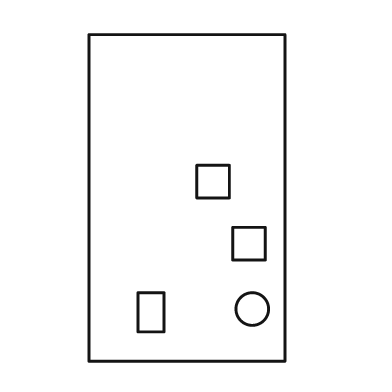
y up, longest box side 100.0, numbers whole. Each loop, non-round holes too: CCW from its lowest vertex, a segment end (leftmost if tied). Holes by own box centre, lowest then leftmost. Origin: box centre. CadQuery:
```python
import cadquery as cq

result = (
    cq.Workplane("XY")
    .moveTo(-30.0, -50.0)
    .lineTo(30.0, -50.0)
    .lineTo(30.0, 50.0)
    .lineTo(-30.0, 50.0)
    .close()
    .moveTo(-15.0, -41.0)
    .lineTo(-7.0, -41.0)
    .lineTo(-7.0, -29.0)
    .lineTo(-15.0, -29.0)
    .close()
    .moveTo(20.0, -34.0)
    .circle(5.0)
    .moveTo(14.0, -19.0)
    .lineTo(24.0, -19.0)
    .lineTo(24.0, -9.0)
    .lineTo(14.0, -9.0)
    .close()
    .moveTo(3.0, 0.0)
    .lineTo(13.0, 0.0)
    .lineTo(13.0, 10.0)
    .lineTo(3.0, 10.0)
    .close()
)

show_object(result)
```